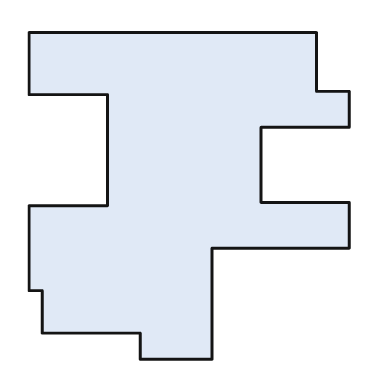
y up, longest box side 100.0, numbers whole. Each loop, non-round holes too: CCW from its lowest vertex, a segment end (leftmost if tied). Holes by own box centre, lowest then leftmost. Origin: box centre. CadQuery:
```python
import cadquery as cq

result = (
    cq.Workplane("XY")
    .moveTo(-15.0, -50.0)
    .lineTo(7.0, -50.0)
    .lineTo(7.0, -16.0)
    .lineTo(49.0, -16.0)
    .lineTo(49.0, -2.0)
    .lineTo(22.0, -2.0)
    .lineTo(22.0, 21.0)
    .lineTo(49.0, 21.0)
    .lineTo(49.0, 32.0)
    .lineTo(39.0, 32.0)
    .lineTo(39.0, 50.0)
    .lineTo(-49.0, 50.0)
    .lineTo(-49.0, 31.0)
    .lineTo(-25.0, 31.0)
    .lineTo(-25.0, -3.0)
    .lineTo(-49.0, -3.0)
    .lineTo(-49.0, -29.0)
    .lineTo(-45.0, -29.0)
    .lineTo(-45.0, -42.0)
    .lineTo(-15.0, -42.0)
    .close()
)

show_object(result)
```